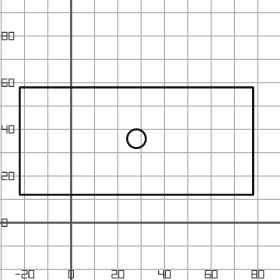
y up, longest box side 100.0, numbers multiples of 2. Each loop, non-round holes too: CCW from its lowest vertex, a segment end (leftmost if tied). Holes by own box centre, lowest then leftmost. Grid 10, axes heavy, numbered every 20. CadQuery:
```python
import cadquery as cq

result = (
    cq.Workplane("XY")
    .moveTo(-22.0, 12.0)
    .lineTo(78.0, 12.0)
    .lineTo(78.0, 58.0)
    .lineTo(-22.0, 58.0)
    .close()
    .moveTo(28.0, 36.0)
    .circle(4.0)
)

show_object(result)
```